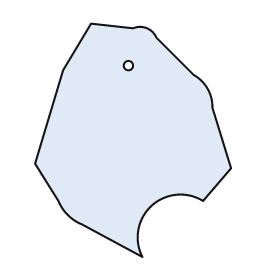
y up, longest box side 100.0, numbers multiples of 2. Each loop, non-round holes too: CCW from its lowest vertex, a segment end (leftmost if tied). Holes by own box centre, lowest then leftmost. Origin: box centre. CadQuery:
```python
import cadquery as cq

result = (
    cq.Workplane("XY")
    .moveTo(4.0, -50.0)
    .threePointArc((8.0, -28.0), (30.0, -26.0))
    .lineTo(42.0, -12.0)
    .lineTo(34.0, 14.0)
    .threePointArc((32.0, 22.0), (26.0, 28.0))
    .lineTo(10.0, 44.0)
    .threePointArc((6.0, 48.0), (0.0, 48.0))
    .lineTo(-18.0, 50.0)
    .lineTo(-30.0, 30.0)
    .lineTo(-42.0, -10.0)
    .lineTo(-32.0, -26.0)
    .threePointArc((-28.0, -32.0), (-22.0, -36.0))
    .close()
    .moveTo(-2.0, 32.0)
    .circle(2.0)
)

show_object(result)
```